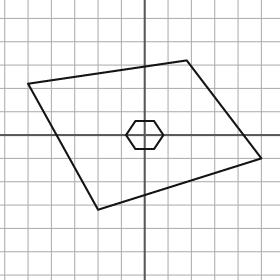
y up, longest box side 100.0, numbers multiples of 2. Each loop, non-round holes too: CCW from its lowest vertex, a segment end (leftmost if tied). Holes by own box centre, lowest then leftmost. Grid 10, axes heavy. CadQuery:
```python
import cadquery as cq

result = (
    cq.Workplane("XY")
    .moveTo(-20.0, -32.0)
    .lineTo(50.0, -10.0)
    .lineTo(18.0, 32.0)
    .lineTo(-50.0, 22.0)
    .close()
    .moveTo(-4.0, -6.0)
    .lineTo(4.0, -6.0)
    .lineTo(8.0, 0.0)
    .lineTo(4.0, 6.0)
    .lineTo(-4.0, 6.0)
    .lineTo(-8.0, 0.0)
    .close()
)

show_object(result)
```